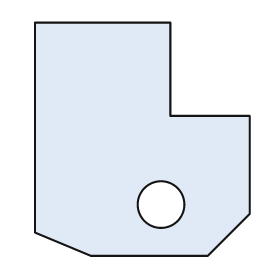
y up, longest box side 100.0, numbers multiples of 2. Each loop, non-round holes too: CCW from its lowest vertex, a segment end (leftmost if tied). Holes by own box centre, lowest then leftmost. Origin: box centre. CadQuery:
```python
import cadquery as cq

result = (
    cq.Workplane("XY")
    .moveTo(-22.0, -50.0)
    .lineTo(28.0, -50.0)
    .lineTo(46.0, -32.0)
    .lineTo(46.0, 10.0)
    .lineTo(12.0, 10.0)
    .lineTo(12.0, 50.0)
    .lineTo(-46.0, 50.0)
    .lineTo(-46.0, -40.0)
    .close()
    .moveTo(8.0, -28.0)
    .circle(10.0)
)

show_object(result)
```